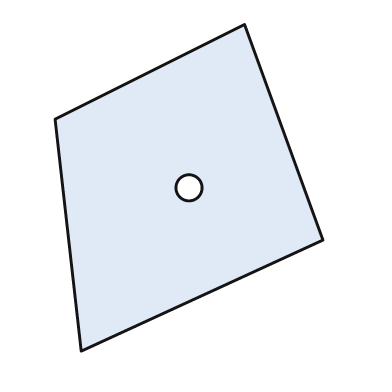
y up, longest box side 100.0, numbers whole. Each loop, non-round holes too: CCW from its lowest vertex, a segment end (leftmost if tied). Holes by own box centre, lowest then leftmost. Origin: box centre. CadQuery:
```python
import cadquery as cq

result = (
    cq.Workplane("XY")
    .moveTo(-33.0, -50.0)
    .lineTo(41.0, -16.0)
    .lineTo(17.0, 50.0)
    .lineTo(-41.0, 21.0)
    .close()
    .moveTo(0.0, 0.0)
    .circle(4.0)
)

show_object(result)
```